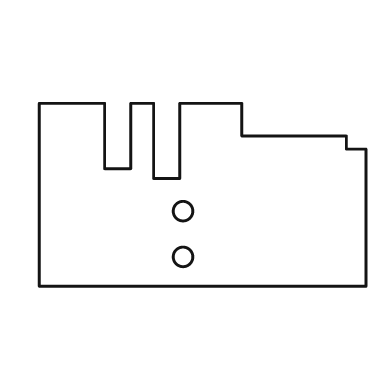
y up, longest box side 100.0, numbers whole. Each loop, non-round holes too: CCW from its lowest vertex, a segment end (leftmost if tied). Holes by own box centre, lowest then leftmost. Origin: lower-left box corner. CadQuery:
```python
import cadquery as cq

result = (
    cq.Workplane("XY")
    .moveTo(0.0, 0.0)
    .lineTo(100.0, 0.0)
    .lineTo(100.0, 42.0)
    .lineTo(94.0, 42.0)
    .lineTo(94.0, 46.0)
    .lineTo(62.0, 46.0)
    .lineTo(62.0, 56.0)
    .lineTo(43.0, 56.0)
    .lineTo(43.0, 33.0)
    .lineTo(35.0, 33.0)
    .lineTo(35.0, 56.0)
    .lineTo(28.0, 56.0)
    .lineTo(28.0, 36.0)
    .lineTo(20.0, 36.0)
    .lineTo(20.0, 56.0)
    .lineTo(0.0, 56.0)
    .close()
    .moveTo(44.0, 9.0)
    .circle(3.0)
    .moveTo(44.0, 23.0)
    .circle(3.0)
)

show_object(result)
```